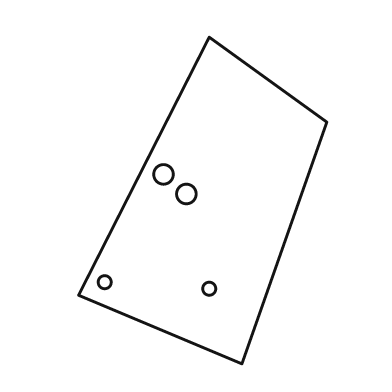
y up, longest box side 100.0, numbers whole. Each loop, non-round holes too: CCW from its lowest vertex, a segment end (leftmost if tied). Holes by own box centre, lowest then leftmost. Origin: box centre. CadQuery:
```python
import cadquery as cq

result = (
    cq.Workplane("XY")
    .moveTo(12.0, -50.0)
    .lineTo(38.0, 24.0)
    .lineTo(2.0, 50.0)
    .lineTo(-38.0, -29.0)
    .close()
    .moveTo(2.0, -27.0)
    .circle(2.0)
    .moveTo(-30.0, -25.0)
    .circle(2.0)
    .moveTo(-5.0, 2.0)
    .circle(3.0)
    .moveTo(-12.0, 8.0)
    .circle(3.0)
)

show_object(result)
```